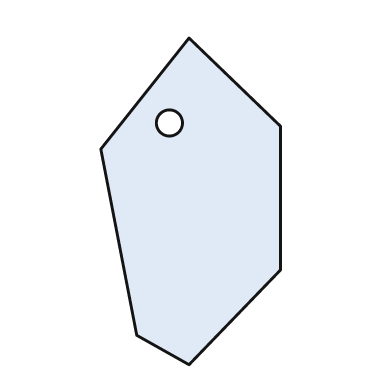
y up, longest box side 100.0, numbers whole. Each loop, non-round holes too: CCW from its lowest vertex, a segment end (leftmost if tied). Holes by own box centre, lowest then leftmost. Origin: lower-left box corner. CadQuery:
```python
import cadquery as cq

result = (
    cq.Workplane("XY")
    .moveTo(27.0, 0.0)
    .lineTo(55.0, 29.0)
    .lineTo(55.0, 73.0)
    .lineTo(27.0, 100.0)
    .lineTo(0.0, 66.0)
    .lineTo(11.0, 9.0)
    .close()
    .moveTo(21.0, 74.0)
    .circle(4.0)
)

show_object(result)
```